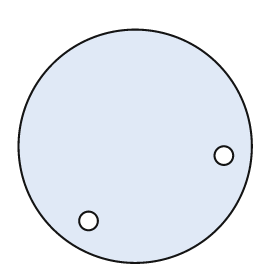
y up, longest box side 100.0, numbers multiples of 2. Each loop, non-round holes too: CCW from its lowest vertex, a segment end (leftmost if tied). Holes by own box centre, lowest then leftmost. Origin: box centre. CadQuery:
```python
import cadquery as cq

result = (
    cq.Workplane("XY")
    .moveTo(0.0, 0.0)
    .circle(50.0)
    .moveTo(-20.0, -32.0)
    .circle(4.0)
    .moveTo(38.0, -4.0)
    .circle(4.0)
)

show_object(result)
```